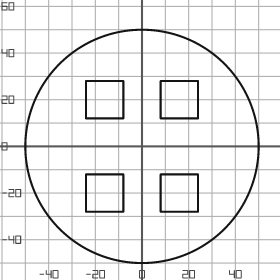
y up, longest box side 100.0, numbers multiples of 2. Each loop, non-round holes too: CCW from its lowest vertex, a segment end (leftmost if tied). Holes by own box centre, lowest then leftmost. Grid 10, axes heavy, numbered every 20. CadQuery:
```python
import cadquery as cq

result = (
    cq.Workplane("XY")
    .moveTo(0.0, 0.0)
    .circle(50.0)
    .moveTo(-24.0, -28.0)
    .lineTo(-8.0, -28.0)
    .lineTo(-8.0, -12.0)
    .lineTo(-24.0, -12.0)
    .close()
    .moveTo(8.0, -28.0)
    .lineTo(24.0, -28.0)
    .lineTo(24.0, -12.0)
    .lineTo(8.0, -12.0)
    .close()
    .moveTo(-24.0, 12.0)
    .lineTo(-8.0, 12.0)
    .lineTo(-8.0, 28.0)
    .lineTo(-24.0, 28.0)
    .close()
    .moveTo(8.0, 12.0)
    .lineTo(24.0, 12.0)
    .lineTo(24.0, 28.0)
    .lineTo(8.0, 28.0)
    .close()
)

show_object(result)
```